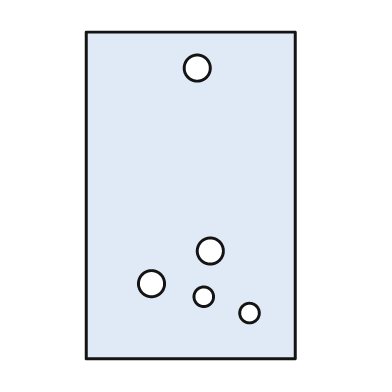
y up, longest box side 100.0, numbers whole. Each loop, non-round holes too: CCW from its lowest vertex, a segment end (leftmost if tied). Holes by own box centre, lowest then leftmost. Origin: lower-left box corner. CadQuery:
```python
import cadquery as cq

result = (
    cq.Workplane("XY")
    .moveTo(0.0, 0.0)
    .lineTo(64.0, 0.0)
    .lineTo(64.0, 100.0)
    .lineTo(0.0, 100.0)
    .close()
    .moveTo(50.0, 14.0)
    .circle(3.0)
    .moveTo(36.0, 19.0)
    .circle(3.0)
    .moveTo(20.0, 23.0)
    .circle(4.0)
    .moveTo(38.0, 33.0)
    .circle(4.0)
    .moveTo(34.0, 89.0)
    .circle(4.0)
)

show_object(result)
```